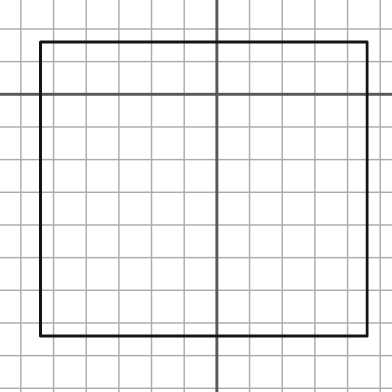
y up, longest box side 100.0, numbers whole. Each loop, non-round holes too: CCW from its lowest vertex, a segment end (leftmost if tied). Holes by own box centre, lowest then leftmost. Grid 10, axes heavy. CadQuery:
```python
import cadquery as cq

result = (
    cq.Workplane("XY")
    .moveTo(-54.0, -74.0)
    .lineTo(46.0, -74.0)
    .lineTo(46.0, 16.0)
    .lineTo(-54.0, 16.0)
    .close()
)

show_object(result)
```